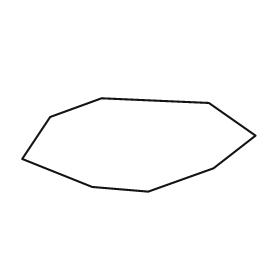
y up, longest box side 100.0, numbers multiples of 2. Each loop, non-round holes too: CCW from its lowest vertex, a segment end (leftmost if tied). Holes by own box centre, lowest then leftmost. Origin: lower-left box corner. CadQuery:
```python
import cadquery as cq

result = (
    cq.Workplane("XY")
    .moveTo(54.0, 0.0)
    .lineTo(82.0, 10.0)
    .lineTo(100.0, 24.0)
    .lineTo(80.0, 38.0)
    .lineTo(34.0, 40.0)
    .lineTo(12.0, 32.0)
    .lineTo(0.0, 14.0)
    .lineTo(30.0, 2.0)
    .close()
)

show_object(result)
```